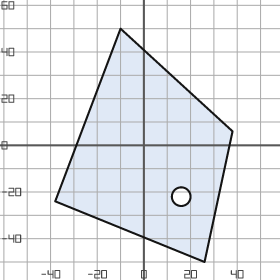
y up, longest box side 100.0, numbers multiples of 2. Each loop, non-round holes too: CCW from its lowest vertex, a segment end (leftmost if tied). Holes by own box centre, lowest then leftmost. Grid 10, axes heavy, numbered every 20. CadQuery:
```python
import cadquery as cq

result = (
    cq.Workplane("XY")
    .moveTo(26.0, -50.0)
    .lineTo(38.0, 6.0)
    .lineTo(-10.0, 50.0)
    .lineTo(-38.0, -24.0)
    .close()
    .moveTo(16.0, -22.0)
    .circle(4.0)
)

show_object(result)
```